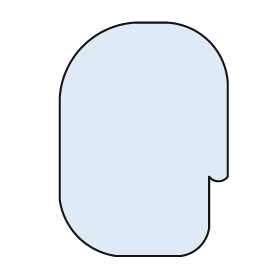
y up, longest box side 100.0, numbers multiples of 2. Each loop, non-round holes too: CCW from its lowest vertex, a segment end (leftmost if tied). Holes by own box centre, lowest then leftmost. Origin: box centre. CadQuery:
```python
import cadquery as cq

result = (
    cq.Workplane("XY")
    .moveTo(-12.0, -50.0)
    .lineTo(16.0, -50.0)
    .threePointArc((24.0, -46.0), (28.0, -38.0))
    .lineTo(28.0, -16.0)
    .threePointArc((32.0, -18.0), (36.0, -16.0))
    .lineTo(36.0, 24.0)
    .threePointArc((28.0, 42.0), (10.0, 50.0))
    .lineTo(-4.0, 50.0)
    .threePointArc((-26.0, 40.0), (-36.0, 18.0))
    .lineTo(-36.0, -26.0)
    .threePointArc((-28.0, -42.0), (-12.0, -50.0))
    .close()
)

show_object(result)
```